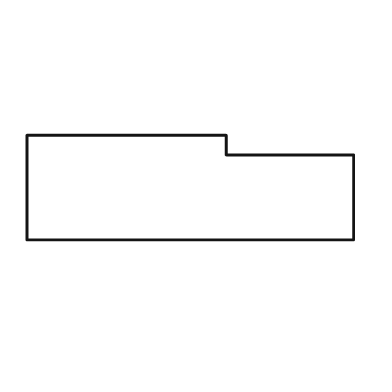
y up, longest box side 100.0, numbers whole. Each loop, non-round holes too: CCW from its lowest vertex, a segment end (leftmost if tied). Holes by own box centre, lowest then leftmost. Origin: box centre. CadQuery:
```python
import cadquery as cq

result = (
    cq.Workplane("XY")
    .moveTo(-50.0, -16.0)
    .lineTo(50.0, -16.0)
    .lineTo(50.0, 10.0)
    .lineTo(11.0, 10.0)
    .lineTo(11.0, 16.0)
    .lineTo(-50.0, 16.0)
    .close()
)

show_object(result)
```